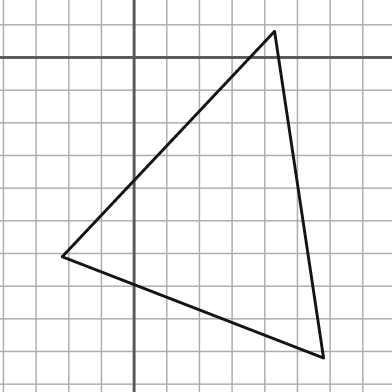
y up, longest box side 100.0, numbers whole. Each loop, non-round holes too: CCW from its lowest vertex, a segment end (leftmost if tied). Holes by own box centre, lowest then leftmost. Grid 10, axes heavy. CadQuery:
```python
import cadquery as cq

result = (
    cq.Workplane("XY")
    .moveTo(58.0, -92.0)
    .lineTo(43.0, 8.0)
    .lineTo(-22.0, -61.0)
    .close()
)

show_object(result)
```